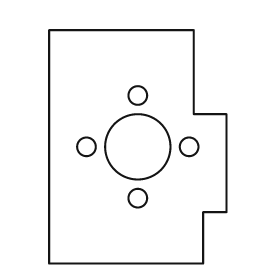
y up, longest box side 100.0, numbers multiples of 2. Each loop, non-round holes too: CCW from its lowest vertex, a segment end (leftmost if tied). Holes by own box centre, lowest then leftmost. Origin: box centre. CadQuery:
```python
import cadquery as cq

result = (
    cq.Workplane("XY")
    .moveTo(-38.0, -50.0)
    .lineTo(28.0, -50.0)
    .lineTo(28.0, -28.0)
    .lineTo(38.0, -28.0)
    .lineTo(38.0, 14.0)
    .lineTo(24.0, 14.0)
    .lineTo(24.0, 50.0)
    .lineTo(-38.0, 50.0)
    .close()
    .moveTo(0.0, -22.0)
    .circle(4.0)
    .moveTo(-22.0, 0.0)
    .circle(4.0)
    .moveTo(0.0, 0.0)
    .circle(14.0)
    .moveTo(22.0, 0.0)
    .circle(4.0)
    .moveTo(0.0, 22.0)
    .circle(4.0)
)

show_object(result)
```